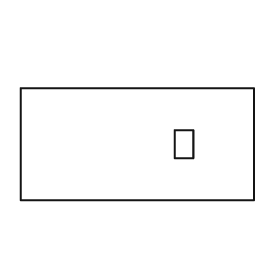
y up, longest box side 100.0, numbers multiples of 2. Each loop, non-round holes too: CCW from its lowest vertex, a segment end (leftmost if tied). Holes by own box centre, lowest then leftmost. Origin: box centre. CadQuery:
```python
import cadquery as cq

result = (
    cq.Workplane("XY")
    .moveTo(-50.0, -24.0)
    .lineTo(50.0, -24.0)
    .lineTo(50.0, 24.0)
    .lineTo(-50.0, 24.0)
    .close()
    .moveTo(16.0, -6.0)
    .lineTo(24.0, -6.0)
    .lineTo(24.0, 6.0)
    .lineTo(16.0, 6.0)
    .close()
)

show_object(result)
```